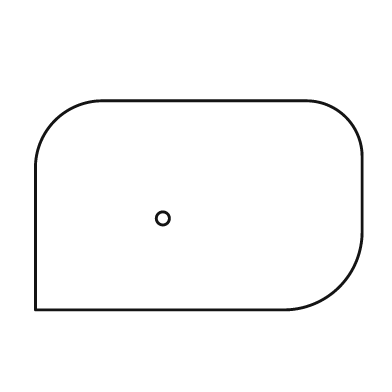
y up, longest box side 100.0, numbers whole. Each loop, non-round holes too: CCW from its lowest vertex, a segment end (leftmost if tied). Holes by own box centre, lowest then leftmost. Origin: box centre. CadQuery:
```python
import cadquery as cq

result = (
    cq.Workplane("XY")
    .moveTo(-50.0, -32.0)
    .lineTo(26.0, -32.0)
    .threePointArc((43.0, -25.0), (50.0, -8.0))
    .lineTo(50.0, 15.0)
    .threePointArc((45.0, 27.0), (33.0, 32.0))
    .lineTo(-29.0, 32.0)
    .threePointArc((-44.0, 26.0), (-50.0, 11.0))
    .close()
    .moveTo(-11.0, -4.0)
    .circle(2.0)
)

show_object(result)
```